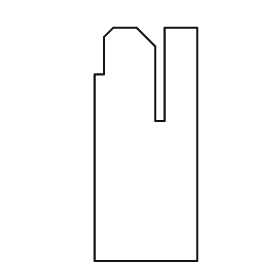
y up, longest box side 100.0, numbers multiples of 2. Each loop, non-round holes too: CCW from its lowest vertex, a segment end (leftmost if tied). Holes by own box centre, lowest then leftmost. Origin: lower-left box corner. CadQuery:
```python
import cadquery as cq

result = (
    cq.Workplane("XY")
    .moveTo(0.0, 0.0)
    .lineTo(44.0, 0.0)
    .lineTo(44.0, 100.0)
    .lineTo(30.0, 100.0)
    .lineTo(30.0, 60.0)
    .lineTo(26.0, 60.0)
    .lineTo(26.0, 92.0)
    .lineTo(18.0, 100.0)
    .lineTo(8.0, 100.0)
    .lineTo(4.0, 96.0)
    .lineTo(4.0, 80.0)
    .lineTo(0.0, 80.0)
    .close()
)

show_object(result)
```